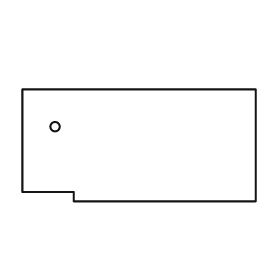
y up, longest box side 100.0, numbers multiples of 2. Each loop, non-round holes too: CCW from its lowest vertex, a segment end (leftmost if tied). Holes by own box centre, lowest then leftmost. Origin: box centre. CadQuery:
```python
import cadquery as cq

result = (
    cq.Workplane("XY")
    .moveTo(-28.0, -24.0)
    .lineTo(50.0, -24.0)
    .lineTo(50.0, 24.0)
    .lineTo(-50.0, 24.0)
    .lineTo(-50.0, -20.0)
    .lineTo(-28.0, -20.0)
    .close()
    .moveTo(-36.0, 8.0)
    .circle(2.0)
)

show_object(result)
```